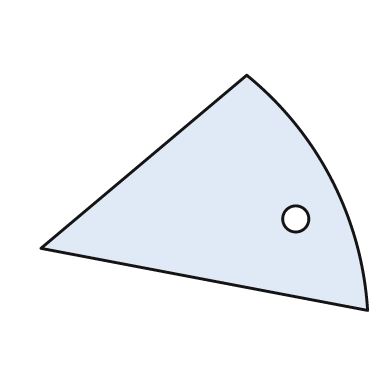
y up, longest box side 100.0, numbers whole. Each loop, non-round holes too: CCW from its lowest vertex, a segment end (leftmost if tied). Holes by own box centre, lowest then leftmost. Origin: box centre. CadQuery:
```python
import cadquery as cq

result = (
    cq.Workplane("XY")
    .moveTo(50.0, -36.0)
    .threePointArc((39.0, 4.0), (13.0, 36.0))
    .lineTo(-50.0, -17.0)
    .close()
    .moveTo(28.0, -8.0)
    .circle(4.0)
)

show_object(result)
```